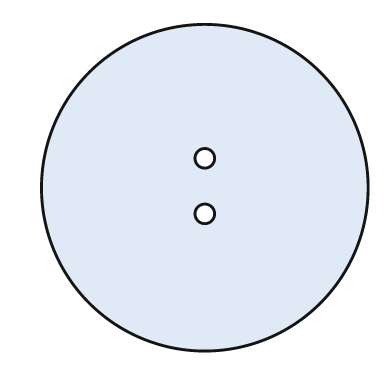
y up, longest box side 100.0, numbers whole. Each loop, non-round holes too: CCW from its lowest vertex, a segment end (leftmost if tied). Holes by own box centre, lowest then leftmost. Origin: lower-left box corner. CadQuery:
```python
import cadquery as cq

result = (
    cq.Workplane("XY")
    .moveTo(50.0, 50.0)
    .circle(50.0)
    .moveTo(50.0, 42.0)
    .circle(3.0)
    .moveTo(50.0, 59.0)
    .circle(3.0)
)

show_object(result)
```